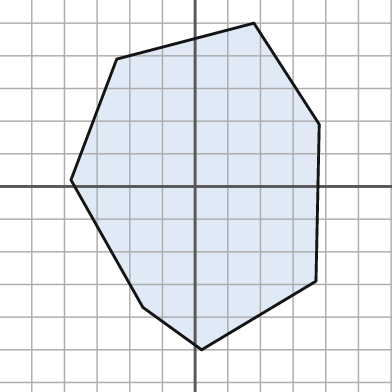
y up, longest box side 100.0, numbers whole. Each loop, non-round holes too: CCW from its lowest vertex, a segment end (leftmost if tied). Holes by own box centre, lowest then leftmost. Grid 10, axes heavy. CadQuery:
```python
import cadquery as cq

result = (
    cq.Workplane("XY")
    .moveTo(2.0, -50.0)
    .lineTo(37.0, -29.0)
    .lineTo(38.0, 19.0)
    .lineTo(18.0, 50.0)
    .lineTo(-24.0, 39.0)
    .lineTo(-38.0, 2.0)
    .lineTo(-16.0, -37.0)
    .close()
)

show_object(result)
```